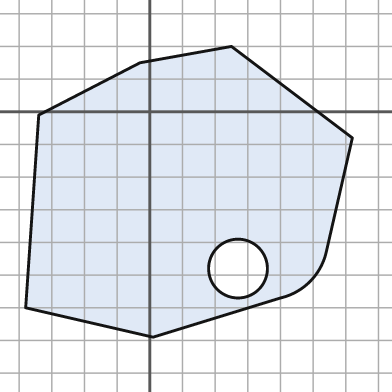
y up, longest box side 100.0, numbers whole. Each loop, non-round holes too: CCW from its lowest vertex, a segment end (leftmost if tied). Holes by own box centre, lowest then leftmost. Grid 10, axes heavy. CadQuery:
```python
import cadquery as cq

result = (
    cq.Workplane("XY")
    .moveTo(1.0, -69.0)
    .lineTo(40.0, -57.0)
    .threePointArc((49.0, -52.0), (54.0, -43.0))
    .lineTo(62.0, -8.0)
    .lineTo(25.0, 20.0)
    .lineTo(-3.0, 15.0)
    .lineTo(-34.0, -1.0)
    .lineTo(-38.0, -60.0)
    .close()
    .moveTo(27.0, -48.0)
    .circle(9.0)
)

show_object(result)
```